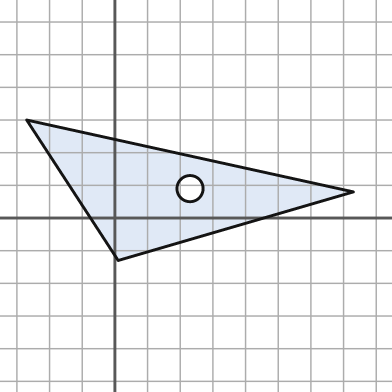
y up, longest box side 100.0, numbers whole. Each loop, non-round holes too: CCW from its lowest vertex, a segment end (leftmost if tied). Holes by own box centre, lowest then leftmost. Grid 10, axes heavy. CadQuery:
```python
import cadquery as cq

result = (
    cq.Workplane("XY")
    .moveTo(1.0, -13.0)
    .lineTo(73.0, 8.0)
    .lineTo(-27.0, 30.0)
    .close()
    .moveTo(23.0, 9.0)
    .circle(4.0)
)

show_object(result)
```